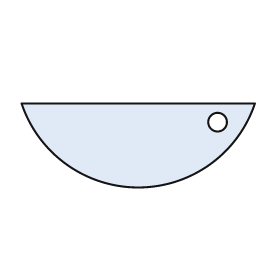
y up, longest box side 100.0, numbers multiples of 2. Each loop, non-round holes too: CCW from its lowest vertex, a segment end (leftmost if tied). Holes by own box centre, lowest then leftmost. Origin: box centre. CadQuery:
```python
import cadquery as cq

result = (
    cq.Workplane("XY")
    .moveTo(-50.0, 18.0)
    .threePointArc((0.0, -18.0), (50.0, 18.0))
    .close()
    .moveTo(34.0, 10.0)
    .circle(4.0)
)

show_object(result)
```